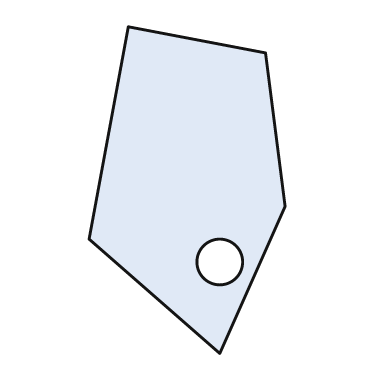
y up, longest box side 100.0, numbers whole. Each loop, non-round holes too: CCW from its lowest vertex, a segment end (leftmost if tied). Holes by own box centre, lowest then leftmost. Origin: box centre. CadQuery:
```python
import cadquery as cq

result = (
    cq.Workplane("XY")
    .moveTo(10.0, -50.0)
    .lineTo(30.0, -5.0)
    .lineTo(24.0, 42.0)
    .lineTo(-18.0, 50.0)
    .lineTo(-30.0, -15.0)
    .close()
    .moveTo(10.0, -22.0)
    .circle(7.0)
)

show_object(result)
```